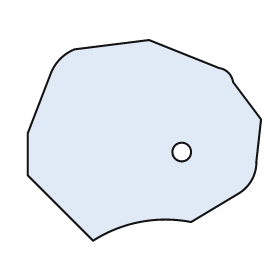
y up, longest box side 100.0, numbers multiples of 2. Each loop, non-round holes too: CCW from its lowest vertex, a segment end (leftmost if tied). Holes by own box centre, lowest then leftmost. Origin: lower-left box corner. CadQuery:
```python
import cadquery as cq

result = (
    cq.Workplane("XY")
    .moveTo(28.0, 0.0)
    .threePointArc((48.0, 8.0), (70.0, 8.0))
    .lineTo(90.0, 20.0)
    .threePointArc((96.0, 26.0), (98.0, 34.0))
    .lineTo(100.0, 52.0)
    .lineTo(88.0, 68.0)
    .threePointArc((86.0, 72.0), (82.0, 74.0))
    .lineTo(52.0, 86.0)
    .lineTo(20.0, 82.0)
    .threePointArc((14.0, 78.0), (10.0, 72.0))
    .lineTo(0.0, 46.0)
    .lineTo(0.0, 28.0)
    .close()
    .moveTo(66.0, 38.0)
    .circle(4.0)
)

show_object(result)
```